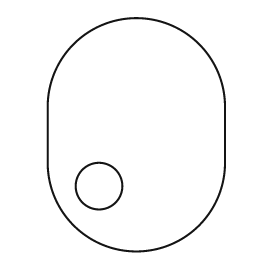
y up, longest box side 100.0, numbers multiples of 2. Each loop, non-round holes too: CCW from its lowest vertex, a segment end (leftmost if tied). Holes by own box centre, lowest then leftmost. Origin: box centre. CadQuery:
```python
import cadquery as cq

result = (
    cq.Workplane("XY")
    .moveTo(-38.0, -12.0)
    .threePointArc((0.0, -50.0), (38.0, -12.0))
    .lineTo(38.0, 12.0)
    .threePointArc((0.0, 50.0), (-38.0, 12.0))
    .close()
    .moveTo(-16.0, -22.0)
    .circle(10.0)
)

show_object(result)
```